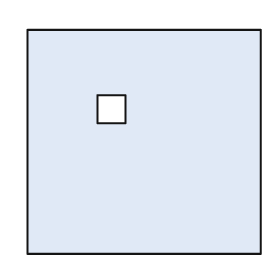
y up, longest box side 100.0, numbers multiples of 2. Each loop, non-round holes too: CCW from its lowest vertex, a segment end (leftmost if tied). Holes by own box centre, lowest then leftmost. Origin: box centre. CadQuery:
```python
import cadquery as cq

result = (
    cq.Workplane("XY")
    .moveTo(-50.0, -48.0)
    .lineTo(50.0, -48.0)
    .lineTo(50.0, 48.0)
    .lineTo(-50.0, 48.0)
    .close()
    .moveTo(-20.0, 8.0)
    .lineTo(-8.0, 8.0)
    .lineTo(-8.0, 20.0)
    .lineTo(-20.0, 20.0)
    .close()
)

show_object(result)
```